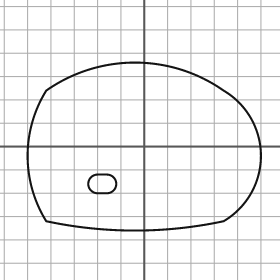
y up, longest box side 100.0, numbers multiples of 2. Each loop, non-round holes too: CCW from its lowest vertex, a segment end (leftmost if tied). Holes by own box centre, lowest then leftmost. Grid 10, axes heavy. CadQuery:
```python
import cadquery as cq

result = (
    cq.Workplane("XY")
    .moveTo(-42.0, -32.0)
    .threePointArc((-4.0, -36.0), (34.0, -32.0))
    .threePointArc((50.0, -4.0), (34.0, 24.0))
    .threePointArc((-4.0, 36.0), (-42.0, 24.0))
    .threePointArc((-50.0, -4.0), (-42.0, -32.0))
    .close()
    .moveTo(-20.0, -20.0)
    .lineTo(-16.0, -20.0)
    .threePointArc((-12.0, -16.0), (-16.0, -12.0))
    .lineTo(-20.0, -12.0)
    .threePointArc((-24.0, -16.0), (-20.0, -20.0))
    .close()
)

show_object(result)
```